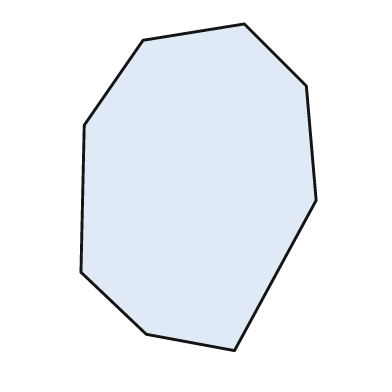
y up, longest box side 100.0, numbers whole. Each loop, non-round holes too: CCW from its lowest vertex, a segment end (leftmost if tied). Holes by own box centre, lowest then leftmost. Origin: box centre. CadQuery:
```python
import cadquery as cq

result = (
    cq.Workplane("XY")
    .moveTo(11.0, -50.0)
    .lineTo(36.0, -4.0)
    .lineTo(33.0, 31.0)
    .lineTo(14.0, 50.0)
    .lineTo(-17.0, 45.0)
    .lineTo(-35.0, 19.0)
    .lineTo(-36.0, -26.0)
    .lineTo(-16.0, -45.0)
    .close()
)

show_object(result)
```